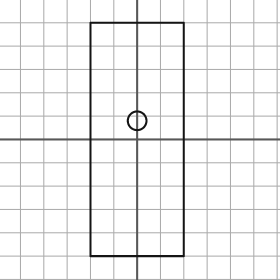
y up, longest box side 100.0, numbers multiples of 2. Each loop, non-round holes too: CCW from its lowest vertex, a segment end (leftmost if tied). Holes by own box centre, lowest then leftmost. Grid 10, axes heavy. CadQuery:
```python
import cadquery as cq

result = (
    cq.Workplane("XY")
    .moveTo(-20.0, -50.0)
    .lineTo(20.0, -50.0)
    .lineTo(20.0, 50.0)
    .lineTo(-20.0, 50.0)
    .close()
    .moveTo(0.0, 8.0)
    .circle(4.0)
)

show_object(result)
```